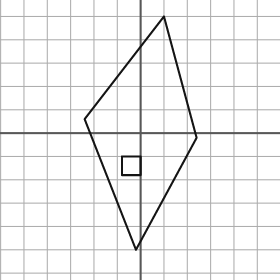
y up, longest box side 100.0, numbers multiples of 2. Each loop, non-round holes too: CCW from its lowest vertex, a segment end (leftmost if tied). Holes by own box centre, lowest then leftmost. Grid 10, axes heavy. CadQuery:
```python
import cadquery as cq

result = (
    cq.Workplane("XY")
    .moveTo(-2.0, -50.0)
    .lineTo(24.0, -2.0)
    .lineTo(10.0, 50.0)
    .lineTo(-24.0, 6.0)
    .close()
    .moveTo(-8.0, -18.0)
    .lineTo(0.0, -18.0)
    .lineTo(0.0, -10.0)
    .lineTo(-8.0, -10.0)
    .close()
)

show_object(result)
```